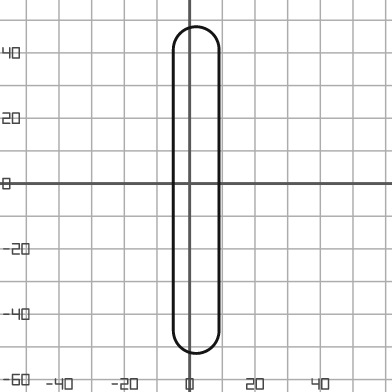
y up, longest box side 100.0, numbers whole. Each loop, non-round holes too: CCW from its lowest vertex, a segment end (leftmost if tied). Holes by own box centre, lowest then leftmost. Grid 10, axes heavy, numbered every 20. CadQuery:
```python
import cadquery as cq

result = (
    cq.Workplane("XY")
    .moveTo(-5.0, -45.0)
    .threePointArc((2.0, -52.0), (9.0, -45.0))
    .lineTo(9.0, 41.0)
    .threePointArc((2.0, 48.0), (-5.0, 41.0))
    .close()
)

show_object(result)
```